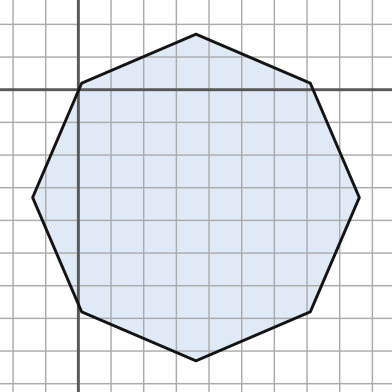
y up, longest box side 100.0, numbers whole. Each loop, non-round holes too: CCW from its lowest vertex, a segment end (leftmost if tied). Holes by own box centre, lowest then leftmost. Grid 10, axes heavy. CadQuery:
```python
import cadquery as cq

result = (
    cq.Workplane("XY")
    .moveTo(36.0, -83.0)
    .lineTo(71.0, -68.0)
    .lineTo(86.0, -33.0)
    .lineTo(71.0, 2.0)
    .lineTo(36.0, 17.0)
    .lineTo(1.0, 2.0)
    .lineTo(-14.0, -33.0)
    .lineTo(1.0, -68.0)
    .close()
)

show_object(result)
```